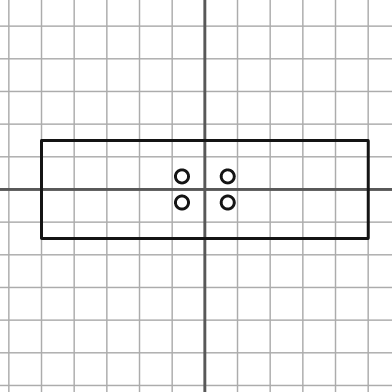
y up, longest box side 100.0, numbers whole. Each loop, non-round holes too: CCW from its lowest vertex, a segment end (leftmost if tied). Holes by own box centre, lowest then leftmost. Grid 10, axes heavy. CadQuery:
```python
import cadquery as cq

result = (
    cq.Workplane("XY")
    .moveTo(-50.0, -15.0)
    .lineTo(50.0, -15.0)
    .lineTo(50.0, 15.0)
    .lineTo(-50.0, 15.0)
    .close()
    .moveTo(-7.0, -4.0)
    .circle(2.0)
    .moveTo(7.0, -4.0)
    .circle(2.0)
    .moveTo(-7.0, 4.0)
    .circle(2.0)
    .moveTo(7.0, 4.0)
    .circle(2.0)
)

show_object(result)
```